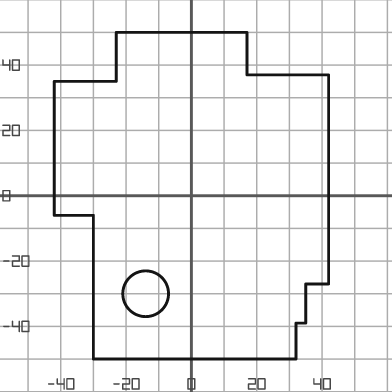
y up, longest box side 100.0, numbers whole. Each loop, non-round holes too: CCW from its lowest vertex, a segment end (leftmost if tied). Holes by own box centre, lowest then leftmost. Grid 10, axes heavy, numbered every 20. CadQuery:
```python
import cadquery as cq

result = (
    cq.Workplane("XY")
    .moveTo(-30.0, -50.0)
    .lineTo(32.0, -50.0)
    .lineTo(32.0, -39.0)
    .lineTo(35.0, -39.0)
    .lineTo(35.0, -27.0)
    .lineTo(42.0, -27.0)
    .lineTo(42.0, 37.0)
    .lineTo(17.0, 37.0)
    .lineTo(17.0, 50.0)
    .lineTo(-23.0, 50.0)
    .lineTo(-23.0, 35.0)
    .lineTo(-42.0, 35.0)
    .lineTo(-42.0, -6.0)
    .lineTo(-30.0, -6.0)
    .close()
    .moveTo(-14.0, -30.0)
    .circle(7.0)
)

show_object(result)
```